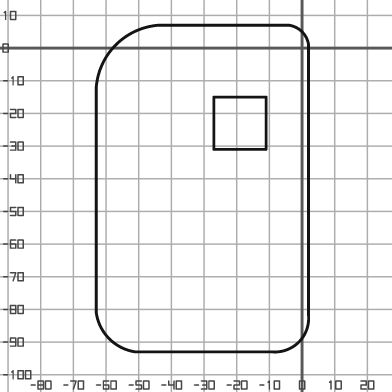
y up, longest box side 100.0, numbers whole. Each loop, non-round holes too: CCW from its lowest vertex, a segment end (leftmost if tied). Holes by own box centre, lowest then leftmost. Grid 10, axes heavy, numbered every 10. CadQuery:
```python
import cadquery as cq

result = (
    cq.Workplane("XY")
    .moveTo(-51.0, -93.0)
    .lineTo(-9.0, -93.0)
    .threePointArc((-1.0, -90.0), (2.0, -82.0))
    .lineTo(2.0, 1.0)
    .threePointArc((0.0, 5.0), (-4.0, 7.0))
    .lineTo(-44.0, 7.0)
    .threePointArc((-57.0, 1.0), (-63.0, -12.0))
    .lineTo(-63.0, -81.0)
    .threePointArc((-59.0, -89.0), (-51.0, -93.0))
    .close()
    .moveTo(-27.0, -31.0)
    .lineTo(-11.0, -31.0)
    .lineTo(-11.0, -15.0)
    .lineTo(-27.0, -15.0)
    .close()
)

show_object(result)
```